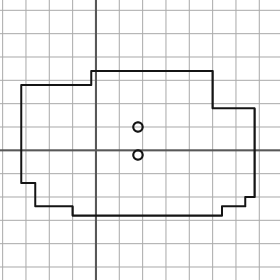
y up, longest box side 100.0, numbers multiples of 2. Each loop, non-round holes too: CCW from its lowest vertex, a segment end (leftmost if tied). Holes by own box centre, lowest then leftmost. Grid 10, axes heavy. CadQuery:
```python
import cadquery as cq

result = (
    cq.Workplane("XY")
    .moveTo(-10.0, -28.0)
    .lineTo(54.0, -28.0)
    .lineTo(54.0, -24.0)
    .lineTo(64.0, -24.0)
    .lineTo(64.0, -20.0)
    .lineTo(68.0, -20.0)
    .lineTo(68.0, 18.0)
    .lineTo(50.0, 18.0)
    .lineTo(50.0, 34.0)
    .lineTo(-2.0, 34.0)
    .lineTo(-2.0, 28.0)
    .lineTo(-32.0, 28.0)
    .lineTo(-32.0, -14.0)
    .lineTo(-26.0, -14.0)
    .lineTo(-26.0, -24.0)
    .lineTo(-10.0, -24.0)
    .close()
    .moveTo(18.0, -2.0)
    .circle(2.0)
    .moveTo(18.0, 10.0)
    .circle(2.0)
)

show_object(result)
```